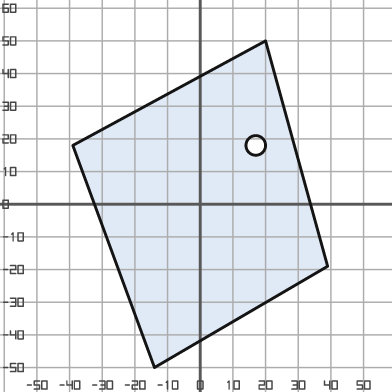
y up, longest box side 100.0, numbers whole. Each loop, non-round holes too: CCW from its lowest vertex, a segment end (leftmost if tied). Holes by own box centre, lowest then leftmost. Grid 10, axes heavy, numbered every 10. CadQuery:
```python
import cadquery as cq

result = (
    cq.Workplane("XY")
    .moveTo(-14.0, -50.0)
    .lineTo(39.0, -19.0)
    .lineTo(20.0, 50.0)
    .lineTo(-39.0, 18.0)
    .close()
    .moveTo(17.0, 18.0)
    .circle(3.0)
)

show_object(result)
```